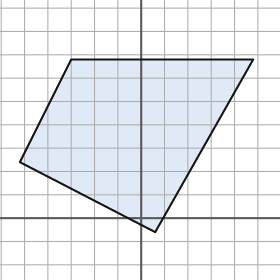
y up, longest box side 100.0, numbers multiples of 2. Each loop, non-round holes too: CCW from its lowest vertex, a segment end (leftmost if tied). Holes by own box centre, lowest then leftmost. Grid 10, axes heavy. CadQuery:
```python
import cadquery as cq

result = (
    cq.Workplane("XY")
    .moveTo(6.0, -6.0)
    .lineTo(48.0, 68.0)
    .lineTo(-30.0, 68.0)
    .lineTo(-52.0, 24.0)
    .close()
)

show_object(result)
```